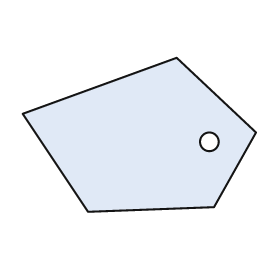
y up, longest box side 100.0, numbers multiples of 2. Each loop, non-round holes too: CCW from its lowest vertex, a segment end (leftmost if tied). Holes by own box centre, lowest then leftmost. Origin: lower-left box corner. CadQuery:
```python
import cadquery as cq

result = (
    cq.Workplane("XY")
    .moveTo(28.0, 0.0)
    .lineTo(82.0, 2.0)
    .lineTo(100.0, 34.0)
    .lineTo(66.0, 66.0)
    .lineTo(0.0, 42.0)
    .close()
    .moveTo(80.0, 30.0)
    .circle(4.0)
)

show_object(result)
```